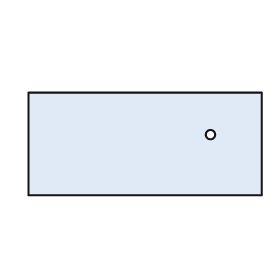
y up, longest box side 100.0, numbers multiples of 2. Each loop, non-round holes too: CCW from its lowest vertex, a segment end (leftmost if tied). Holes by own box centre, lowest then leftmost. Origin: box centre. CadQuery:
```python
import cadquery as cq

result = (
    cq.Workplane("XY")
    .moveTo(-50.0, -22.0)
    .lineTo(50.0, -22.0)
    .lineTo(50.0, 22.0)
    .lineTo(-50.0, 22.0)
    .close()
    .moveTo(28.0, 4.0)
    .circle(2.0)
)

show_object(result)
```